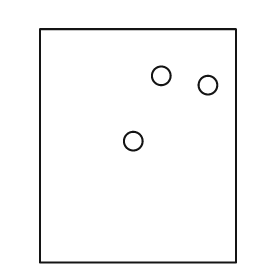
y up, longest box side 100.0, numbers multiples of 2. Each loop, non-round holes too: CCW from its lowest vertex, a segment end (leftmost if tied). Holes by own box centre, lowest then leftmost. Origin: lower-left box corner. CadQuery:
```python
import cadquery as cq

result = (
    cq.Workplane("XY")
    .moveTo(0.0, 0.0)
    .lineTo(84.0, 0.0)
    .lineTo(84.0, 100.0)
    .lineTo(0.0, 100.0)
    .close()
    .moveTo(40.0, 52.0)
    .circle(4.0)
    .moveTo(72.0, 76.0)
    .circle(4.0)
    .moveTo(52.0, 80.0)
    .circle(4.0)
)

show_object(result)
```